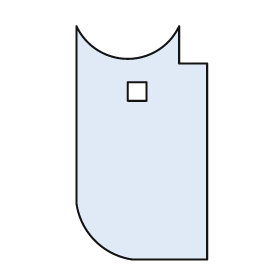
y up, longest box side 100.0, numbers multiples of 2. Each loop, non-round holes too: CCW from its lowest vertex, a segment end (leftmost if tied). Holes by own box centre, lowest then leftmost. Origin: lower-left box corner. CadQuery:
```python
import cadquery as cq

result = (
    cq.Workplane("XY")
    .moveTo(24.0, 0.0)
    .lineTo(56.0, 0.0)
    .lineTo(56.0, 84.0)
    .lineTo(44.0, 84.0)
    .lineTo(44.0, 100.0)
    .threePointArc((22.0, 86.0), (0.0, 100.0))
    .lineTo(0.0, 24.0)
    .threePointArc((8.0, 8.0), (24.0, 0.0))
    .close()
    .moveTo(22.0, 68.0)
    .lineTo(30.0, 68.0)
    .lineTo(30.0, 76.0)
    .lineTo(22.0, 76.0)
    .close()
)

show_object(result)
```